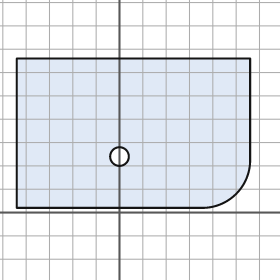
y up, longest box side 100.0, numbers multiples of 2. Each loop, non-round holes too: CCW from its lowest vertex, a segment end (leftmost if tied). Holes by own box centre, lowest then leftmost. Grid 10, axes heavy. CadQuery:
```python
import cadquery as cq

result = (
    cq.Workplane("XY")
    .moveTo(-44.0, 2.0)
    .lineTo(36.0, 2.0)
    .threePointArc((50.0, 8.0), (56.0, 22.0))
    .lineTo(56.0, 66.0)
    .lineTo(-44.0, 66.0)
    .close()
    .moveTo(0.0, 24.0)
    .circle(4.0)
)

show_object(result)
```